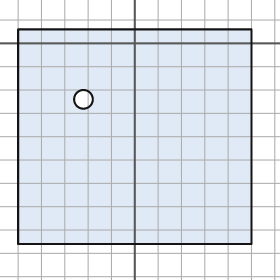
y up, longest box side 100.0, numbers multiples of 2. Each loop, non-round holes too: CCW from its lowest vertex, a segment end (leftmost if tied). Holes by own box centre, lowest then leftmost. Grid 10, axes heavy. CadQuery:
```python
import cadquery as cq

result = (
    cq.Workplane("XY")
    .moveTo(-50.0, -86.0)
    .lineTo(50.0, -86.0)
    .lineTo(50.0, 6.0)
    .lineTo(-50.0, 6.0)
    .close()
    .moveTo(-22.0, -24.0)
    .circle(4.0)
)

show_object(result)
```